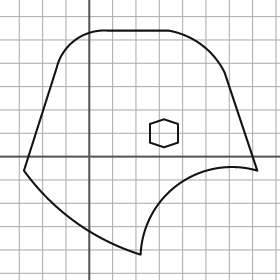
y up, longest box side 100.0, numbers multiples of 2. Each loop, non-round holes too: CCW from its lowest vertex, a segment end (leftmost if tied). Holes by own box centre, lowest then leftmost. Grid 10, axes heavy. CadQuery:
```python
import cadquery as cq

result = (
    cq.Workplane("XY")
    .moveTo(22.0, -42.0)
    .threePointArc((38.0, -12.0), (72.0, -6.0))
    .lineTo(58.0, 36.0)
    .threePointArc((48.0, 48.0), (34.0, 54.0))
    .lineTo(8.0, 54.0)
    .threePointArc((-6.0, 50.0), (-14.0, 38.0))
    .lineTo(-28.0, -6.0)
    .threePointArc((-6.0, -28.0), (22.0, -42.0))
    .close()
    .moveTo(32.0, 4.0)
    .lineTo(38.0, 6.0)
    .lineTo(38.0, 14.0)
    .lineTo(32.0, 16.0)
    .lineTo(26.0, 14.0)
    .lineTo(26.0, 6.0)
    .close()
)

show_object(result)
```